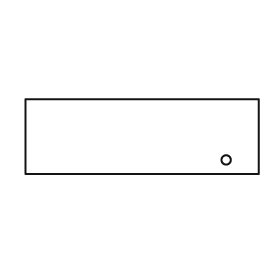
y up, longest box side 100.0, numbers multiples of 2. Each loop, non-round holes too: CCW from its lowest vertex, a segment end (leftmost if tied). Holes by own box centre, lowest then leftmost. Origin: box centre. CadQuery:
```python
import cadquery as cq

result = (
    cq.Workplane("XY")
    .moveTo(-50.0, -16.0)
    .lineTo(50.0, -16.0)
    .lineTo(50.0, 16.0)
    .lineTo(-50.0, 16.0)
    .close()
    .moveTo(36.0, -10.0)
    .circle(2.0)
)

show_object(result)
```